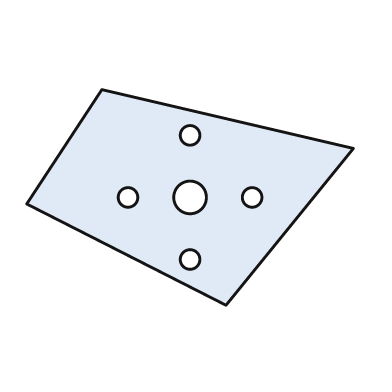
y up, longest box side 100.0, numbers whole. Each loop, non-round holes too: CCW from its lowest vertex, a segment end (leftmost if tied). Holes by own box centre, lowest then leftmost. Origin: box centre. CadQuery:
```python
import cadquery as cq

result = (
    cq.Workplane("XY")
    .moveTo(11.0, -33.0)
    .lineTo(50.0, 15.0)
    .lineTo(-27.0, 33.0)
    .lineTo(-50.0, -2.0)
    .close()
    .moveTo(0.0, -19.0)
    .circle(3.0)
    .moveTo(-19.0, 0.0)
    .circle(3.0)
    .moveTo(0.0, 0.0)
    .circle(5.0)
    .moveTo(19.0, 0.0)
    .circle(3.0)
    .moveTo(0.0, 19.0)
    .circle(3.0)
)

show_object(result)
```